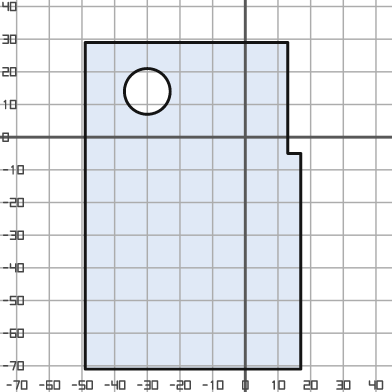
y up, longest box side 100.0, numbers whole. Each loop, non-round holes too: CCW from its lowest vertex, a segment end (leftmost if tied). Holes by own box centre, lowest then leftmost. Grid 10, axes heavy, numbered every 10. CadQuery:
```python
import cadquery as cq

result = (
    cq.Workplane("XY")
    .moveTo(-49.0, -71.0)
    .lineTo(17.0, -71.0)
    .lineTo(17.0, -5.0)
    .lineTo(13.0, -5.0)
    .lineTo(13.0, 29.0)
    .lineTo(-49.0, 29.0)
    .close()
    .moveTo(-30.0, 14.0)
    .circle(7.0)
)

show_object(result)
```